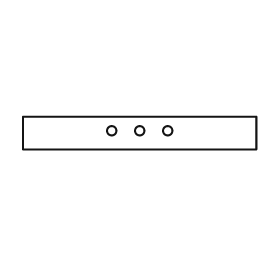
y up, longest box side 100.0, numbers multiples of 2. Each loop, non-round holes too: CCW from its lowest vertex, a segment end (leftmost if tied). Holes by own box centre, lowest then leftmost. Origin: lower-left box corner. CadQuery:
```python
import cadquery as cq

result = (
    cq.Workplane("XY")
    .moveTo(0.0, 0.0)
    .lineTo(100.0, 0.0)
    .lineTo(100.0, 14.0)
    .lineTo(0.0, 14.0)
    .close()
    .moveTo(38.0, 8.0)
    .circle(2.0)
    .moveTo(50.0, 8.0)
    .circle(2.0)
    .moveTo(62.0, 8.0)
    .circle(2.0)
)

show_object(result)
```